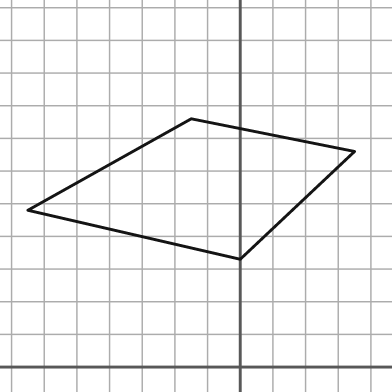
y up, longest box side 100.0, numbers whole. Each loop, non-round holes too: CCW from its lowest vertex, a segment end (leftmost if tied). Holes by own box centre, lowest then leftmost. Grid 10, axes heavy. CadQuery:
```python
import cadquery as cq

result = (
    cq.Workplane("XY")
    .moveTo(0.0, 33.0)
    .lineTo(35.0, 66.0)
    .lineTo(-15.0, 76.0)
    .lineTo(-65.0, 48.0)
    .close()
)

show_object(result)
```